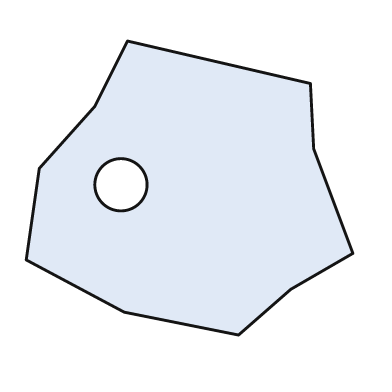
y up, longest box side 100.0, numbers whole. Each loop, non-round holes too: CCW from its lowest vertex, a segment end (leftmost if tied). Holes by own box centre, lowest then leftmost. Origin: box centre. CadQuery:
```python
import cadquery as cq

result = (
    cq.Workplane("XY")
    .moveTo(15.0, -45.0)
    .lineTo(31.0, -31.0)
    .lineTo(50.0, -20.0)
    .lineTo(38.0, 12.0)
    .lineTo(37.0, 32.0)
    .lineTo(-19.0, 45.0)
    .lineTo(-29.0, 25.0)
    .lineTo(-46.0, 6.0)
    .lineTo(-50.0, -22.0)
    .lineTo(-20.0, -38.0)
    .close()
    .moveTo(-21.0, 1.0)
    .circle(8.0)
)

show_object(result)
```